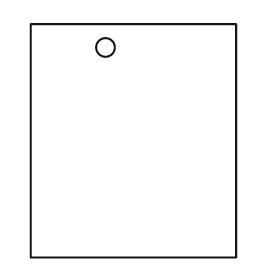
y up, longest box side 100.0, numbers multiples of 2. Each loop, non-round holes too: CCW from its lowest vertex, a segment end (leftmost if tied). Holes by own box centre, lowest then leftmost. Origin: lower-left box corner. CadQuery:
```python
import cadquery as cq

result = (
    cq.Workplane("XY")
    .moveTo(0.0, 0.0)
    .lineTo(88.0, 0.0)
    .lineTo(88.0, 100.0)
    .lineTo(0.0, 100.0)
    .close()
    .moveTo(32.0, 90.0)
    .circle(4.0)
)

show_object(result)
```